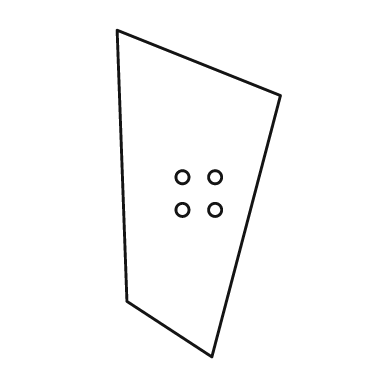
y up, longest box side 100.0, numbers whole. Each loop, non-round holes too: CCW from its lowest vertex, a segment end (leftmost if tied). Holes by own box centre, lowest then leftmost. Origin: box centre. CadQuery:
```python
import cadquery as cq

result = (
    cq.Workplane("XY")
    .moveTo(4.0, -50.0)
    .lineTo(25.0, 30.0)
    .lineTo(-25.0, 50.0)
    .lineTo(-22.0, -33.0)
    .close()
    .moveTo(-5.0, -5.0)
    .circle(2.0)
    .moveTo(5.0, -5.0)
    .circle(2.0)
    .moveTo(-5.0, 5.0)
    .circle(2.0)
    .moveTo(5.0, 5.0)
    .circle(2.0)
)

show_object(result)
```